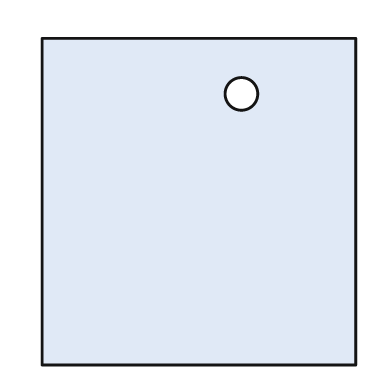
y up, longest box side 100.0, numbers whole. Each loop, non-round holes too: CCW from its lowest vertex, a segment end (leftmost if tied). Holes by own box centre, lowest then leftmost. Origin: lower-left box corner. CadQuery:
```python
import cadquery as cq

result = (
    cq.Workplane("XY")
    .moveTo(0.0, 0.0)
    .lineTo(96.0, 0.0)
    .lineTo(96.0, 100.0)
    .lineTo(0.0, 100.0)
    .close()
    .moveTo(61.0, 83.0)
    .circle(5.0)
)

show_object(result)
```